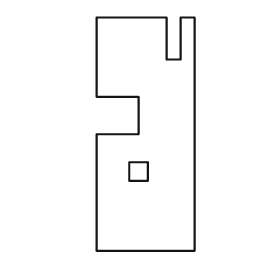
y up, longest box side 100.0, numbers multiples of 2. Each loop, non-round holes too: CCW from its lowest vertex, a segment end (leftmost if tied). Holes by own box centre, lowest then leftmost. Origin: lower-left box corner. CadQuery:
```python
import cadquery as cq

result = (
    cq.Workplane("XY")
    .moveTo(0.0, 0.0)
    .lineTo(42.0, 0.0)
    .lineTo(42.0, 100.0)
    .lineTo(36.0, 100.0)
    .lineTo(36.0, 82.0)
    .lineTo(30.0, 82.0)
    .lineTo(30.0, 100.0)
    .lineTo(0.0, 100.0)
    .lineTo(0.0, 66.0)
    .lineTo(18.0, 66.0)
    .lineTo(18.0, 50.0)
    .lineTo(0.0, 50.0)
    .close()
    .moveTo(14.0, 30.0)
    .lineTo(22.0, 30.0)
    .lineTo(22.0, 38.0)
    .lineTo(14.0, 38.0)
    .close()
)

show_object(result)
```